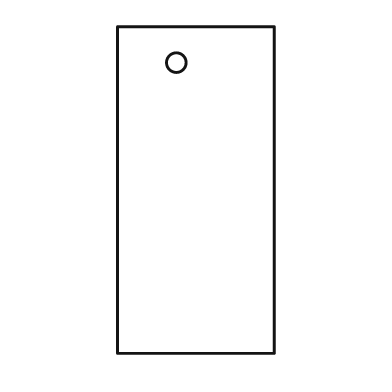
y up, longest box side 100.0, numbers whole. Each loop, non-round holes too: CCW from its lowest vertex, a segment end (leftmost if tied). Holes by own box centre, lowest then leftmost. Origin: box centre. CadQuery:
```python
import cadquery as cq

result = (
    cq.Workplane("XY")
    .moveTo(-24.0, -50.0)
    .lineTo(24.0, -50.0)
    .lineTo(24.0, 50.0)
    .lineTo(-24.0, 50.0)
    .close()
    .moveTo(-6.0, 39.0)
    .circle(3.0)
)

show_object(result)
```